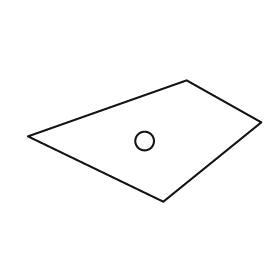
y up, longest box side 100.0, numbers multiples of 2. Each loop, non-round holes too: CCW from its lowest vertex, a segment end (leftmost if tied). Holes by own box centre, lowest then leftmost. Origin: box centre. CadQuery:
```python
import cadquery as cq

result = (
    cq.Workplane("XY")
    .moveTo(8.0, -26.0)
    .lineTo(50.0, 8.0)
    .lineTo(18.0, 26.0)
    .lineTo(-50.0, 2.0)
    .close()
    .moveTo(0.0, 0.0)
    .circle(4.0)
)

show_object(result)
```